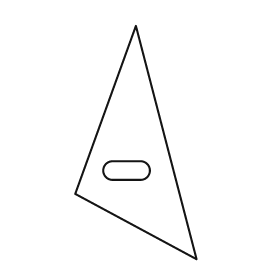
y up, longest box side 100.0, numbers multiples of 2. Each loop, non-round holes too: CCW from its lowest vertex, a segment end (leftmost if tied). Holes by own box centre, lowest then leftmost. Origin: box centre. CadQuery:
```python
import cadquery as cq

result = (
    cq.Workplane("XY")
    .moveTo(26.0, -50.0)
    .lineTo(0.0, 50.0)
    .lineTo(-26.0, -22.0)
    .close()
    .moveTo(-10.0, -16.0)
    .lineTo(2.0, -16.0)
    .threePointArc((6.0, -12.0), (2.0, -8.0))
    .lineTo(-10.0, -8.0)
    .threePointArc((-14.0, -12.0), (-10.0, -16.0))
    .close()
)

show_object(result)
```